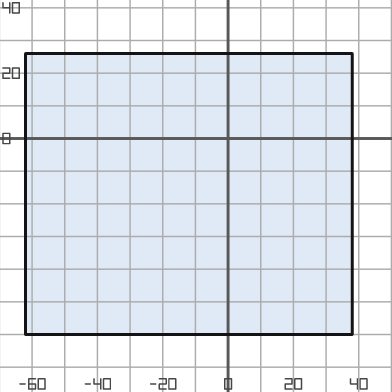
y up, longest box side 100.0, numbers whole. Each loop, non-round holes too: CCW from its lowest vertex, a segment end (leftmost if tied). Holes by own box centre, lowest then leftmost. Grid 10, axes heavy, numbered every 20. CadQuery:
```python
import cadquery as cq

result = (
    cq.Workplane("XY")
    .moveTo(-62.0, -60.0)
    .lineTo(38.0, -60.0)
    .lineTo(38.0, 26.0)
    .lineTo(-62.0, 26.0)
    .close()
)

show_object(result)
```